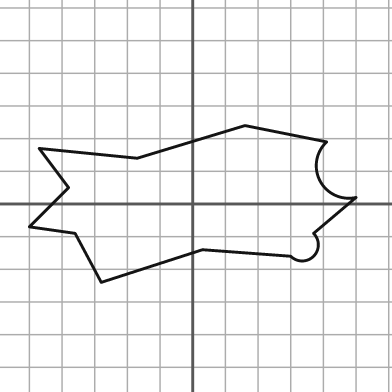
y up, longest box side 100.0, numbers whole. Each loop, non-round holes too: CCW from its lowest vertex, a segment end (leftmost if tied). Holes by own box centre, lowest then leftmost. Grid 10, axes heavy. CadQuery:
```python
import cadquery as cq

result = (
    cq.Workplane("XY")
    .moveTo(-28.0, -24.0)
    .lineTo(3.0, -14.0)
    .lineTo(30.0, -16.0)
    .threePointArc((37.0, -16.0), (37.0, -9.0))
    .lineTo(50.0, 2.0)
    .threePointArc((39.0, 7.0), (41.0, 19.0))
    .lineTo(16.0, 24.0)
    .lineTo(-17.0, 14.0)
    .lineTo(-47.0, 17.0)
    .lineTo(-38.0, 5.0)
    .lineTo(-50.0, -7.0)
    .lineTo(-36.0, -9.0)
    .close()
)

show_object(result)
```